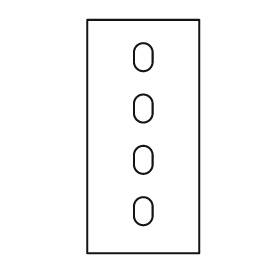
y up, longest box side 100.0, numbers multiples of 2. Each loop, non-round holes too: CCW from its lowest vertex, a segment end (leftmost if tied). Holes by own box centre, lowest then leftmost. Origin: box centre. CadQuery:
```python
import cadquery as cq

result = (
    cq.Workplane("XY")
    .moveTo(-24.0, -50.0)
    .lineTo(24.0, -50.0)
    .lineTo(24.0, 50.0)
    .lineTo(-24.0, 50.0)
    .close()
    .moveTo(-4.0, -34.0)
    .threePointArc((0.0, -38.0), (4.0, -34.0))
    .lineTo(4.0, -30.0)
    .threePointArc((0.0, -26.0), (-4.0, -30.0))
    .close()
    .moveTo(-4.0, -12.0)
    .threePointArc((0.0, -16.0), (4.0, -12.0))
    .lineTo(4.0, -8.0)
    .threePointArc((0.0, -4.0), (-4.0, -8.0))
    .close()
    .moveTo(-4.0, 10.0)
    .threePointArc((0.0, 6.0), (4.0, 10.0))
    .lineTo(4.0, 14.0)
    .threePointArc((0.0, 18.0), (-4.0, 14.0))
    .close()
    .moveTo(-4.0, 32.0)
    .threePointArc((0.0, 28.0), (4.0, 32.0))
    .lineTo(4.0, 36.0)
    .threePointArc((0.0, 40.0), (-4.0, 36.0))
    .close()
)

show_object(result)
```